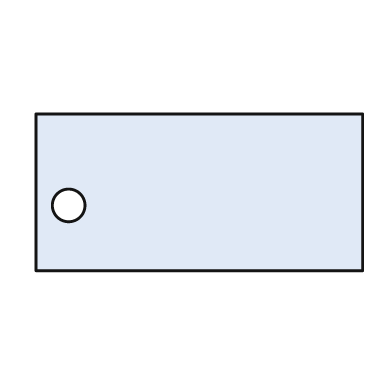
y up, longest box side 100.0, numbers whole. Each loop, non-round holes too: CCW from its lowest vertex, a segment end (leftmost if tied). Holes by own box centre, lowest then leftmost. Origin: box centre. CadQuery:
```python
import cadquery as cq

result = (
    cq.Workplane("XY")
    .moveTo(-50.0, -24.0)
    .lineTo(50.0, -24.0)
    .lineTo(50.0, 24.0)
    .lineTo(-50.0, 24.0)
    .close()
    .moveTo(-40.0, -4.0)
    .circle(5.0)
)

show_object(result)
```